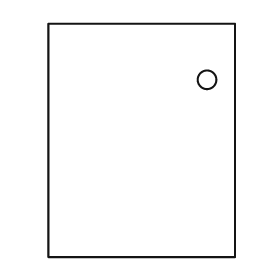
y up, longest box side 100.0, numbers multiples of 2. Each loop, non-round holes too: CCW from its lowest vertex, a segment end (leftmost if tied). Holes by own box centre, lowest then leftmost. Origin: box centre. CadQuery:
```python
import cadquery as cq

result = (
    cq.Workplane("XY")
    .moveTo(-40.0, -50.0)
    .lineTo(40.0, -50.0)
    .lineTo(40.0, 50.0)
    .lineTo(-40.0, 50.0)
    .close()
    .moveTo(28.0, 26.0)
    .circle(4.0)
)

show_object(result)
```